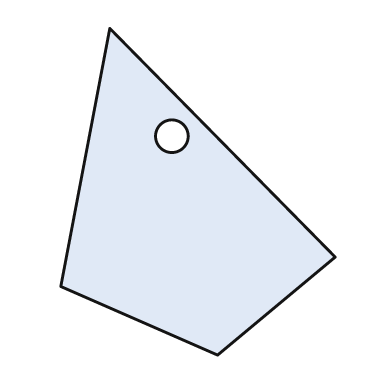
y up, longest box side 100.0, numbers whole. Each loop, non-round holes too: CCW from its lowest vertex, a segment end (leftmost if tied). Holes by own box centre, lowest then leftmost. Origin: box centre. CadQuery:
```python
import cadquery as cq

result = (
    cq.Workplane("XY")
    .moveTo(6.0, -50.0)
    .lineTo(42.0, -20.0)
    .lineTo(-27.0, 50.0)
    .lineTo(-42.0, -29.0)
    .close()
    .moveTo(-8.0, 17.0)
    .circle(5.0)
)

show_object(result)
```